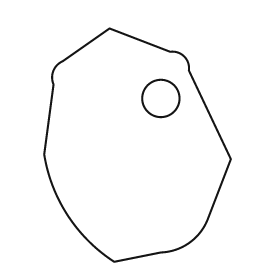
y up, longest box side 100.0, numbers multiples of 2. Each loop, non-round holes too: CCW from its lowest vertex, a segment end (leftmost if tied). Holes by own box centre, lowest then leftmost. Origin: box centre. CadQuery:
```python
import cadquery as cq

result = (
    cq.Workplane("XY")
    .moveTo(-10.0, -50.0)
    .lineTo(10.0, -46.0)
    .threePointArc((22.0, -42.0), (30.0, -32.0))
    .lineTo(40.0, -6.0)
    .lineTo(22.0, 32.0)
    .threePointArc((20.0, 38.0), (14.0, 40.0))
    .lineTo(-12.0, 50.0)
    .lineTo(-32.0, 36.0)
    .threePointArc((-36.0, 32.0), (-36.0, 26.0))
    .lineTo(-40.0, -4.0)
    .threePointArc((-30.0, -30.0), (-10.0, -50.0))
    .close()
    .moveTo(10.0, 20.0)
    .circle(8.0)
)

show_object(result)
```